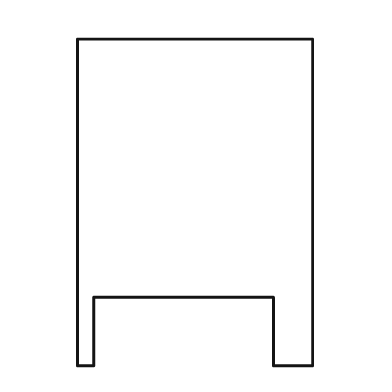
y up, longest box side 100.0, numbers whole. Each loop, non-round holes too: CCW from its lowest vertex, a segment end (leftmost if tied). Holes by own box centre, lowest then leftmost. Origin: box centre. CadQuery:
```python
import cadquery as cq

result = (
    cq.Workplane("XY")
    .moveTo(-36.0, -50.0)
    .lineTo(-31.0, -50.0)
    .lineTo(-31.0, -29.0)
    .lineTo(24.0, -29.0)
    .lineTo(24.0, -50.0)
    .lineTo(36.0, -50.0)
    .lineTo(36.0, 50.0)
    .lineTo(-36.0, 50.0)
    .close()
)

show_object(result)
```